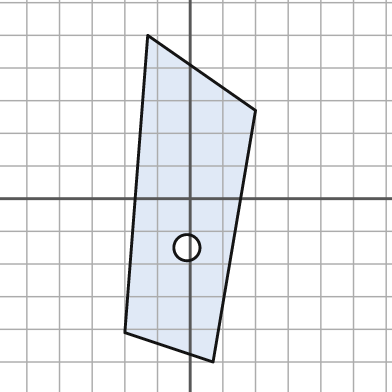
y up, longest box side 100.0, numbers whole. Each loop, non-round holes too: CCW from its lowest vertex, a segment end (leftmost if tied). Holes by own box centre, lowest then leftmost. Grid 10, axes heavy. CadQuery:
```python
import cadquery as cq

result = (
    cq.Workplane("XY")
    .moveTo(7.0, -50.0)
    .lineTo(20.0, 27.0)
    .lineTo(-13.0, 50.0)
    .lineTo(-20.0, -41.0)
    .close()
    .moveTo(-1.0, -15.0)
    .circle(4.0)
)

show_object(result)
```